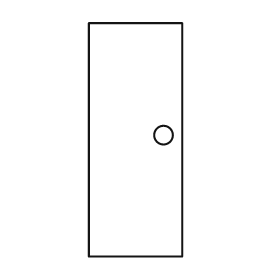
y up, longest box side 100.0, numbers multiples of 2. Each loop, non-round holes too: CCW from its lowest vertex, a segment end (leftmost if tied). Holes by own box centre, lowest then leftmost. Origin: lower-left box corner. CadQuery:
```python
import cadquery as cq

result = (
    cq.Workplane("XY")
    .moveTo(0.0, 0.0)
    .lineTo(40.0, 0.0)
    .lineTo(40.0, 100.0)
    .lineTo(0.0, 100.0)
    .close()
    .moveTo(32.0, 52.0)
    .circle(4.0)
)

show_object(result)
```